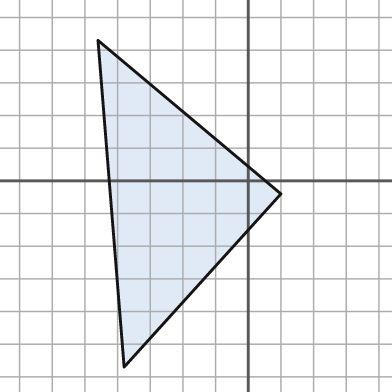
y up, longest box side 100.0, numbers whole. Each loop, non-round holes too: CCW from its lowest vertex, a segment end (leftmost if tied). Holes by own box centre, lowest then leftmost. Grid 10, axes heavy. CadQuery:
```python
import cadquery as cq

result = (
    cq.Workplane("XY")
    .moveTo(-38.0, -57.0)
    .lineTo(10.0, -4.0)
    .lineTo(-46.0, 43.0)
    .close()
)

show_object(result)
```